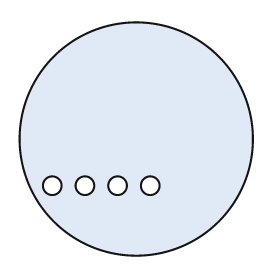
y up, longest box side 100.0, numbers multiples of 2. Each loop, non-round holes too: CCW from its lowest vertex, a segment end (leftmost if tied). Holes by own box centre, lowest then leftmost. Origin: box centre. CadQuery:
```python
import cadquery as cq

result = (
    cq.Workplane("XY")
    .moveTo(0.0, 0.0)
    .circle(50.0)
    .moveTo(-36.0, -20.0)
    .circle(4.0)
    .moveTo(-22.0, -20.0)
    .circle(4.0)
    .moveTo(-8.0, -20.0)
    .circle(4.0)
    .moveTo(6.0, -20.0)
    .circle(4.0)
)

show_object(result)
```